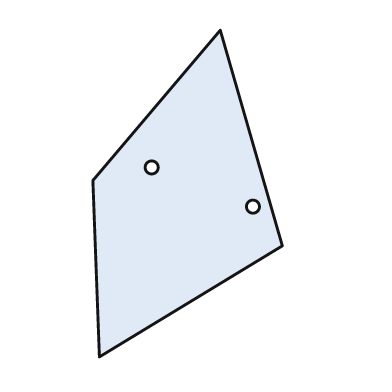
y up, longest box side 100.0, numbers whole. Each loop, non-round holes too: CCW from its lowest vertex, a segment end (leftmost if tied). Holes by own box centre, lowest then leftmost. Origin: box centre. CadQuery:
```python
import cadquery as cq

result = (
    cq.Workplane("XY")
    .moveTo(-27.0, -50.0)
    .lineTo(29.0, -16.0)
    .lineTo(10.0, 50.0)
    .lineTo(-29.0, 4.0)
    .close()
    .moveTo(20.0, -4.0)
    .circle(2.0)
    .moveTo(-11.0, 8.0)
    .circle(2.0)
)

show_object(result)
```